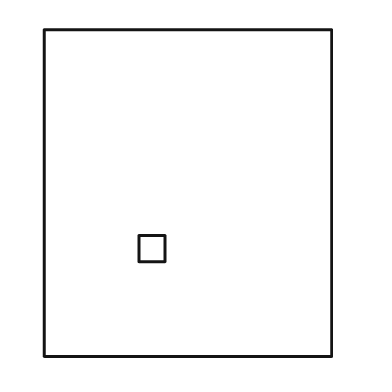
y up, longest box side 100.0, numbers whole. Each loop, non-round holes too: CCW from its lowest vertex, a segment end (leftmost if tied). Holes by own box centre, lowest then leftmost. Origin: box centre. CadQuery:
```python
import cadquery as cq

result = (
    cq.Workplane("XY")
    .moveTo(-44.0, -50.0)
    .lineTo(44.0, -50.0)
    .lineTo(44.0, 50.0)
    .lineTo(-44.0, 50.0)
    .close()
    .moveTo(-15.0, -21.0)
    .lineTo(-7.0, -21.0)
    .lineTo(-7.0, -13.0)
    .lineTo(-15.0, -13.0)
    .close()
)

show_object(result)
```